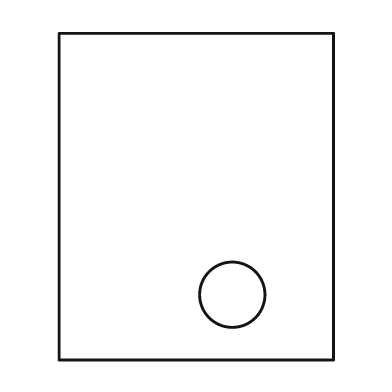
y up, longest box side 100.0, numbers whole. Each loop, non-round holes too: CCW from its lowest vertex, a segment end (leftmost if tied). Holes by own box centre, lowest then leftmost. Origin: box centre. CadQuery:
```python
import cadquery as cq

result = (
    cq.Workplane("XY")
    .moveTo(-42.0, -50.0)
    .lineTo(42.0, -50.0)
    .lineTo(42.0, 50.0)
    .lineTo(-42.0, 50.0)
    .close()
    .moveTo(11.0, -30.0)
    .circle(10.0)
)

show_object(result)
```